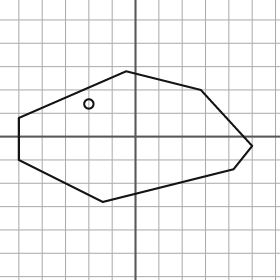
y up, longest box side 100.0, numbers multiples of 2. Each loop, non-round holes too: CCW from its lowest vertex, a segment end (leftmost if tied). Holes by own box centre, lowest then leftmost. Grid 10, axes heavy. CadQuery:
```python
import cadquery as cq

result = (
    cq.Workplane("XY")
    .moveTo(-14.0, -28.0)
    .lineTo(42.0, -14.0)
    .lineTo(50.0, -4.0)
    .lineTo(28.0, 20.0)
    .lineTo(-4.0, 28.0)
    .lineTo(-50.0, 8.0)
    .lineTo(-50.0, -10.0)
    .close()
    .moveTo(-20.0, 14.0)
    .circle(2.0)
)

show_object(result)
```